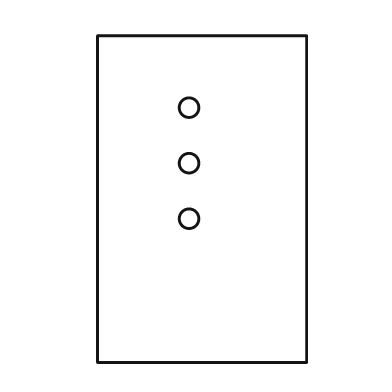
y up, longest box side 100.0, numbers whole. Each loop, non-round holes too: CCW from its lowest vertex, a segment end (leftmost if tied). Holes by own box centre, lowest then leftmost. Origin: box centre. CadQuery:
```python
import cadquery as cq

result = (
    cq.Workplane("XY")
    .moveTo(-32.0, -50.0)
    .lineTo(32.0, -50.0)
    .lineTo(32.0, 50.0)
    .lineTo(-32.0, 50.0)
    .close()
    .moveTo(-4.0, -6.0)
    .circle(3.0)
    .moveTo(-4.0, 11.0)
    .circle(3.0)
    .moveTo(-4.0, 28.0)
    .circle(3.0)
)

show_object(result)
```